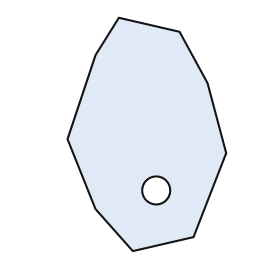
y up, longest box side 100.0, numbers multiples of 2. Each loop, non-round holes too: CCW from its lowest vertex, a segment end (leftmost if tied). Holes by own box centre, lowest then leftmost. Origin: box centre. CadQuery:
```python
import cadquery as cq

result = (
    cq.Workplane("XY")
    .moveTo(-6.0, -50.0)
    .lineTo(20.0, -44.0)
    .lineTo(34.0, -8.0)
    .lineTo(26.0, 22.0)
    .lineTo(14.0, 44.0)
    .lineTo(-12.0, 50.0)
    .lineTo(-22.0, 34.0)
    .lineTo(-34.0, -2.0)
    .lineTo(-22.0, -32.0)
    .close()
    .moveTo(4.0, -24.0)
    .circle(6.0)
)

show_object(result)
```